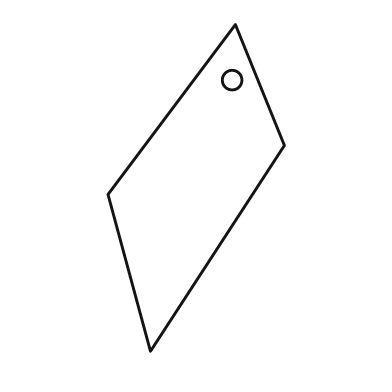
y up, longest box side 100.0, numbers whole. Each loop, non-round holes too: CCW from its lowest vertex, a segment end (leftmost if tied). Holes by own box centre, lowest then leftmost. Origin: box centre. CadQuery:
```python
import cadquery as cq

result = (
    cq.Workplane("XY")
    .moveTo(-14.0, -50.0)
    .lineTo(27.0, 13.0)
    .lineTo(12.0, 50.0)
    .lineTo(-27.0, -2.0)
    .close()
    .moveTo(11.0, 33.0)
    .circle(3.0)
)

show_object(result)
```